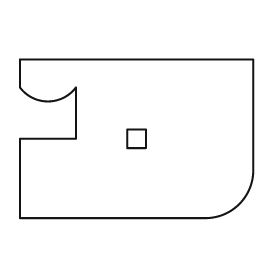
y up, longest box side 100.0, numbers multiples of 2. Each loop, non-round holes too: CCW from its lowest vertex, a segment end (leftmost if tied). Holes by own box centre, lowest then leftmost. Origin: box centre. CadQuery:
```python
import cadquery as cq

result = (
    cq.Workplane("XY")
    .moveTo(-50.0, -34.0)
    .lineTo(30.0, -34.0)
    .threePointArc((44.0, -28.0), (50.0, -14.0))
    .lineTo(50.0, 34.0)
    .lineTo(-50.0, 34.0)
    .lineTo(-50.0, 22.0)
    .threePointArc((-38.0, 16.0), (-26.0, 22.0))
    .lineTo(-26.0, 0.0)
    .lineTo(-50.0, 0.0)
    .close()
    .moveTo(-4.0, -4.0)
    .lineTo(4.0, -4.0)
    .lineTo(4.0, 4.0)
    .lineTo(-4.0, 4.0)
    .close()
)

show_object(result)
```